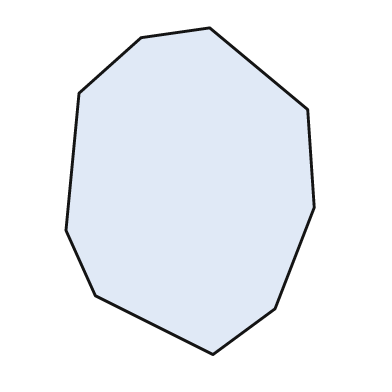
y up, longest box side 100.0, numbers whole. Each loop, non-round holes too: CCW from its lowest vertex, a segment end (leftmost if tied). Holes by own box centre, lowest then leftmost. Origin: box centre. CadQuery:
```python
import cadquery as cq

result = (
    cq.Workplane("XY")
    .moveTo(7.0, -50.0)
    .lineTo(26.0, -36.0)
    .lineTo(38.0, -5.0)
    .lineTo(36.0, 25.0)
    .lineTo(6.0, 50.0)
    .lineTo(-15.0, 47.0)
    .lineTo(-34.0, 30.0)
    .lineTo(-38.0, -12.0)
    .lineTo(-29.0, -32.0)
    .close()
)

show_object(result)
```